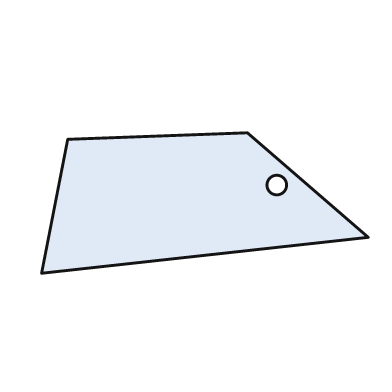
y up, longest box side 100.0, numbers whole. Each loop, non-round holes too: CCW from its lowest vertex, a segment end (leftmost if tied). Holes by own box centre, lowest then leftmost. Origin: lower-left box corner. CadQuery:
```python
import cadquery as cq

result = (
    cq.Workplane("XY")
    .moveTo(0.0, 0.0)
    .lineTo(100.0, 11.0)
    .lineTo(63.0, 43.0)
    .lineTo(8.0, 41.0)
    .close()
    .moveTo(72.0, 27.0)
    .circle(3.0)
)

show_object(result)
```